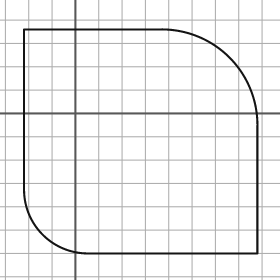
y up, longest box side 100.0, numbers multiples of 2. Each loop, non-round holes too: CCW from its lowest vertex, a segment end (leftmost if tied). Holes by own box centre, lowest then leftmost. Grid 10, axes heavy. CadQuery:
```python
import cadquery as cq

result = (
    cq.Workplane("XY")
    .moveTo(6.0, -60.0)
    .lineTo(78.0, -60.0)
    .lineTo(78.0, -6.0)
    .threePointArc((66.0, 24.0), (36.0, 36.0))
    .lineTo(-22.0, 36.0)
    .lineTo(-22.0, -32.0)
    .threePointArc((-14.0, -52.0), (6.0, -60.0))
    .close()
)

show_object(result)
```